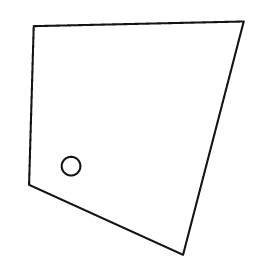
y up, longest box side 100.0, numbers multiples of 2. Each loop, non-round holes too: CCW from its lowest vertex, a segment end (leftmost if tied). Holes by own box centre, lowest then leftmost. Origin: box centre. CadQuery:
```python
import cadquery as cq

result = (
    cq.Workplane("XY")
    .moveTo(20.0, -50.0)
    .lineTo(46.0, 50.0)
    .lineTo(-44.0, 48.0)
    .lineTo(-46.0, -20.0)
    .close()
    .moveTo(-28.0, -12.0)
    .circle(4.0)
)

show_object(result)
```